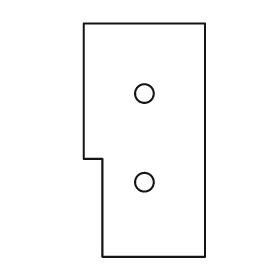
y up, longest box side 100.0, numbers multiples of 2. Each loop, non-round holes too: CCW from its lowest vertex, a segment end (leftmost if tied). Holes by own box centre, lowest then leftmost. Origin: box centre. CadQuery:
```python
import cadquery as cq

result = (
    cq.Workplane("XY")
    .moveTo(-18.0, -50.0)
    .lineTo(26.0, -50.0)
    .lineTo(26.0, 50.0)
    .lineTo(-26.0, 50.0)
    .lineTo(-26.0, -8.0)
    .lineTo(-18.0, -8.0)
    .close()
    .moveTo(0.0, -18.0)
    .circle(4.0)
    .moveTo(0.0, 20.0)
    .circle(4.0)
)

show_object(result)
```